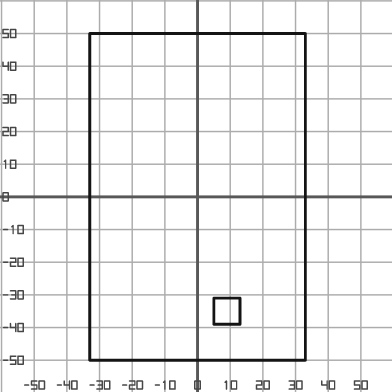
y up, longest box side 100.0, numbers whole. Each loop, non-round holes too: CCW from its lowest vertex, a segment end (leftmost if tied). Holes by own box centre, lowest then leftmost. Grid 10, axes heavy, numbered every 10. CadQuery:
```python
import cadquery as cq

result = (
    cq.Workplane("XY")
    .moveTo(-33.0, -50.0)
    .lineTo(33.0, -50.0)
    .lineTo(33.0, 50.0)
    .lineTo(-33.0, 50.0)
    .close()
    .moveTo(5.0, -39.0)
    .lineTo(13.0, -39.0)
    .lineTo(13.0, -31.0)
    .lineTo(5.0, -31.0)
    .close()
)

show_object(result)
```